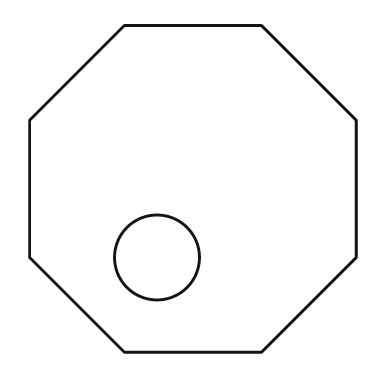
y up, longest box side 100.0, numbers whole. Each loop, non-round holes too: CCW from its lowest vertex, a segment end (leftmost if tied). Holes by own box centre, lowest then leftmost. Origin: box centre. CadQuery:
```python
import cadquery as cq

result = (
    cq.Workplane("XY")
    .moveTo(-21.0, -50.0)
    .lineTo(21.0, -50.0)
    .lineTo(50.0, -21.0)
    .lineTo(50.0, 21.0)
    .lineTo(21.0, 50.0)
    .lineTo(-21.0, 50.0)
    .lineTo(-50.0, 21.0)
    .lineTo(-50.0, -21.0)
    .close()
    .moveTo(-11.0, -21.0)
    .circle(13.0)
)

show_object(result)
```